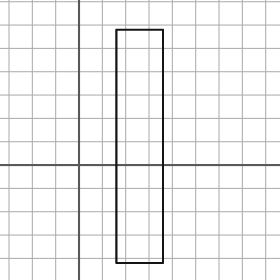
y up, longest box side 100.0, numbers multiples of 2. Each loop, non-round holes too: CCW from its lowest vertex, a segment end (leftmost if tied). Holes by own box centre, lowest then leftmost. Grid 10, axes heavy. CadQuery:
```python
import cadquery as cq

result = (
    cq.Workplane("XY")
    .moveTo(16.0, -42.0)
    .lineTo(36.0, -42.0)
    .lineTo(36.0, 58.0)
    .lineTo(16.0, 58.0)
    .close()
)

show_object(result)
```